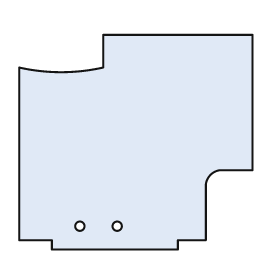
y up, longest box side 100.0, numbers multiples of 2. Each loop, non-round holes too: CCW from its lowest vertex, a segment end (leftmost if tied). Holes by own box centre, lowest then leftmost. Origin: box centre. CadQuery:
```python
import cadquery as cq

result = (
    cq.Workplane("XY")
    .moveTo(-36.0, -46.0)
    .lineTo(18.0, -46.0)
    .lineTo(18.0, -42.0)
    .lineTo(30.0, -42.0)
    .lineTo(30.0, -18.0)
    .threePointArc((32.0, -14.0), (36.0, -12.0))
    .lineTo(50.0, -12.0)
    .lineTo(50.0, 46.0)
    .lineTo(-14.0, 46.0)
    .lineTo(-14.0, 32.0)
    .threePointArc((-32.0, 30.0), (-50.0, 32.0))
    .lineTo(-50.0, -42.0)
    .lineTo(-36.0, -42.0)
    .close()
    .moveTo(-24.0, -36.0)
    .circle(2.0)
    .moveTo(-8.0, -36.0)
    .circle(2.0)
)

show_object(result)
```